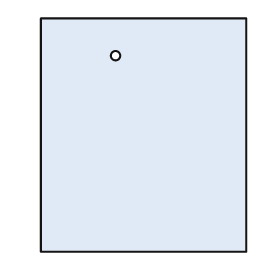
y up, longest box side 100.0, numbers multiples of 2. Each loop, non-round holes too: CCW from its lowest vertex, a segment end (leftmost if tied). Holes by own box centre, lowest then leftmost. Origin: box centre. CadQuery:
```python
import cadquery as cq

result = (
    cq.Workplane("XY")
    .moveTo(-44.0, -50.0)
    .lineTo(44.0, -50.0)
    .lineTo(44.0, 50.0)
    .lineTo(-44.0, 50.0)
    .close()
    .moveTo(-12.0, 34.0)
    .circle(2.0)
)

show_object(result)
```